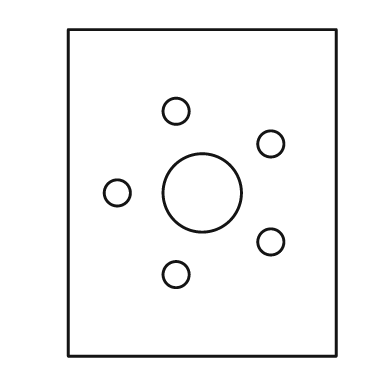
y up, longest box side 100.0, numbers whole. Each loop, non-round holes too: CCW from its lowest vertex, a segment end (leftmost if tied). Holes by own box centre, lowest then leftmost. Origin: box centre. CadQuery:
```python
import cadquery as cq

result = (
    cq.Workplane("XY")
    .moveTo(-41.0, -50.0)
    .lineTo(41.0, -50.0)
    .lineTo(41.0, 50.0)
    .lineTo(-41.0, 50.0)
    .close()
    .moveTo(-8.0, -25.0)
    .circle(4.0)
    .moveTo(21.0, -15.0)
    .circle(4.0)
    .moveTo(-26.0, 0.0)
    .circle(4.0)
    .moveTo(0.0, 0.0)
    .circle(12.0)
    .moveTo(21.0, 15.0)
    .circle(4.0)
    .moveTo(-8.0, 25.0)
    .circle(4.0)
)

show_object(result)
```